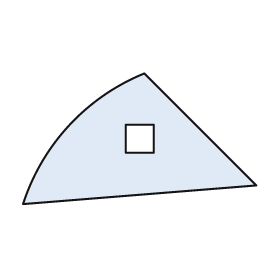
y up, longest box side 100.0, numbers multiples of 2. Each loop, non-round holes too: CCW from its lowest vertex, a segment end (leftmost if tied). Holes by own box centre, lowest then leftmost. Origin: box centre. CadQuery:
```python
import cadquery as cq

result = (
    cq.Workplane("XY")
    .moveTo(-50.0, -28.0)
    .lineTo(50.0, -20.0)
    .lineTo(2.0, 28.0)
    .threePointArc((-30.0, 6.0), (-50.0, -28.0))
    .close()
    .moveTo(-6.0, -6.0)
    .lineTo(6.0, -6.0)
    .lineTo(6.0, 6.0)
    .lineTo(-6.0, 6.0)
    .close()
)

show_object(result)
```